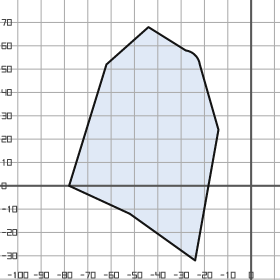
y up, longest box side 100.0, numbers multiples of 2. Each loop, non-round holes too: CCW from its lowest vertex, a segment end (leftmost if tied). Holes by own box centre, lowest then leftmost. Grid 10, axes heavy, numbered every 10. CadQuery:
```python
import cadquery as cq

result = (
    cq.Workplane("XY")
    .moveTo(-24.0, -32.0)
    .lineTo(-14.0, 24.0)
    .lineTo(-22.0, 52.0)
    .threePointArc((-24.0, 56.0), (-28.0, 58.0))
    .lineTo(-44.0, 68.0)
    .lineTo(-62.0, 52.0)
    .lineTo(-78.0, 0.0)
    .lineTo(-52.0, -12.0)
    .close()
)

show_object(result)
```